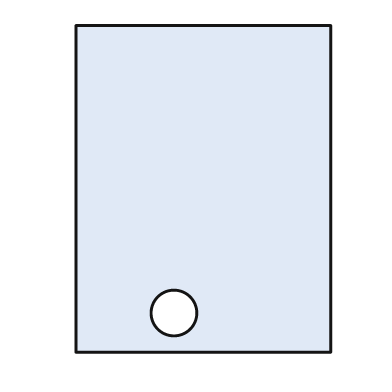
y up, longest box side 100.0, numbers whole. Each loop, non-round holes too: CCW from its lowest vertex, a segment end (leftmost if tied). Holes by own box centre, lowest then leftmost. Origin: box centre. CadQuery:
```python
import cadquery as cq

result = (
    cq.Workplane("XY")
    .moveTo(-39.0, -50.0)
    .lineTo(39.0, -50.0)
    .lineTo(39.0, 50.0)
    .lineTo(-39.0, 50.0)
    .close()
    .moveTo(-9.0, -38.0)
    .circle(7.0)
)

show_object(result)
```